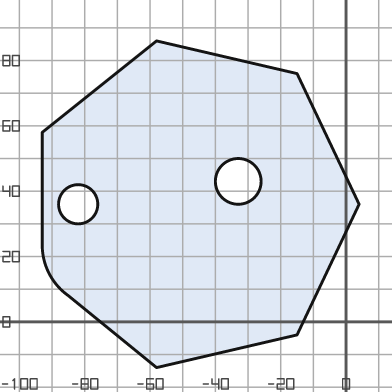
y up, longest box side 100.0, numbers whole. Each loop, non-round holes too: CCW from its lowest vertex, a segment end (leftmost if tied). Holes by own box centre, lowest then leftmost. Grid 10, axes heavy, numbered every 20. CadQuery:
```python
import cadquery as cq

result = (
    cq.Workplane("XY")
    .moveTo(-58.0, -14.0)
    .lineTo(-15.0, -4.0)
    .lineTo(4.0, 36.0)
    .lineTo(-15.0, 76.0)
    .lineTo(-58.0, 86.0)
    .lineTo(-93.0, 58.0)
    .lineTo(-93.0, 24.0)
    .threePointArc((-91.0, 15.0), (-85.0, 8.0))
    .close()
    .moveTo(-82.0, 36.0)
    .circle(6.0)
    .moveTo(-33.0, 43.0)
    .circle(7.0)
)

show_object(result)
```